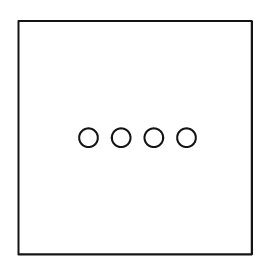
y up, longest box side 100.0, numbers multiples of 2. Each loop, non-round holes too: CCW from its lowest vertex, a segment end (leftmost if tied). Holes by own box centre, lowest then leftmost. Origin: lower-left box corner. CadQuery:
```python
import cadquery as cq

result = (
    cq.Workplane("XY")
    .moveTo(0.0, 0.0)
    .lineTo(100.0, 0.0)
    .lineTo(100.0, 100.0)
    .lineTo(0.0, 100.0)
    .close()
    .moveTo(30.0, 50.0)
    .circle(4.0)
    .moveTo(44.0, 50.0)
    .circle(4.0)
    .moveTo(58.0, 50.0)
    .circle(4.0)
    .moveTo(72.0, 50.0)
    .circle(4.0)
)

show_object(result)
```